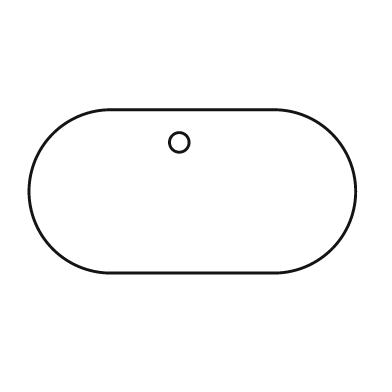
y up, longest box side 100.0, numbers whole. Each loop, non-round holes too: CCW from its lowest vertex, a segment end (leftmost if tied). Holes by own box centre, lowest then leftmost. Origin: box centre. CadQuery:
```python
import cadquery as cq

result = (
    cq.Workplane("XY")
    .moveTo(-25.0, -25.0)
    .lineTo(25.0, -25.0)
    .threePointArc((50.0, 0.0), (25.0, 25.0))
    .lineTo(-25.0, 25.0)
    .threePointArc((-50.0, 0.0), (-25.0, -25.0))
    .close()
    .moveTo(-4.0, 15.0)
    .circle(3.0)
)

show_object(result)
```